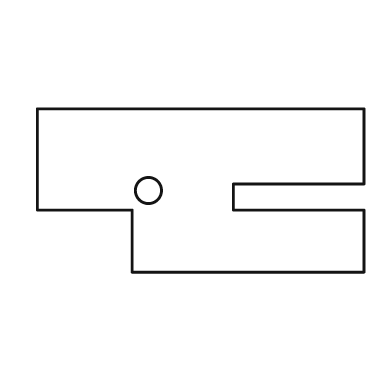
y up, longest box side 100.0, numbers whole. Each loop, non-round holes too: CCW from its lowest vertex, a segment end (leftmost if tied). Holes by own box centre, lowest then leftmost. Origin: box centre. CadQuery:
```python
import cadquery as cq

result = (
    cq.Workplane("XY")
    .moveTo(-21.0, -25.0)
    .lineTo(50.0, -25.0)
    .lineTo(50.0, -6.0)
    .lineTo(10.0, -6.0)
    .lineTo(10.0, 2.0)
    .lineTo(50.0, 2.0)
    .lineTo(50.0, 25.0)
    .lineTo(-50.0, 25.0)
    .lineTo(-50.0, -6.0)
    .lineTo(-21.0, -6.0)
    .close()
    .moveTo(-16.0, 0.0)
    .circle(4.0)
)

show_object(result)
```